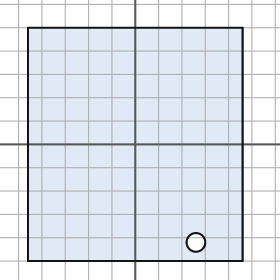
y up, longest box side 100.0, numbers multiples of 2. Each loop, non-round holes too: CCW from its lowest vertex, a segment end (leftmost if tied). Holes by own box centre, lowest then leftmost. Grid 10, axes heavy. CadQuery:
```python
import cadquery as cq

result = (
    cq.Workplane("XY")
    .moveTo(-46.0, -50.0)
    .lineTo(46.0, -50.0)
    .lineTo(46.0, 50.0)
    .lineTo(-46.0, 50.0)
    .close()
    .moveTo(26.0, -42.0)
    .circle(4.0)
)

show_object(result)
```